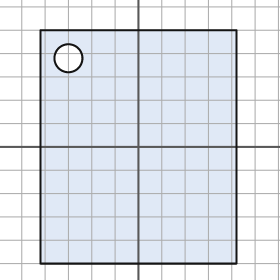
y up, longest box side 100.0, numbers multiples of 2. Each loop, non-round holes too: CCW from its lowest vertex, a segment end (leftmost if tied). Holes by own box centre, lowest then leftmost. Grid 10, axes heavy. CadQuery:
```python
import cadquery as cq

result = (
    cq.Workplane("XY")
    .moveTo(-42.0, -50.0)
    .lineTo(42.0, -50.0)
    .lineTo(42.0, 50.0)
    .lineTo(-42.0, 50.0)
    .close()
    .moveTo(-30.0, 38.0)
    .circle(6.0)
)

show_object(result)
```